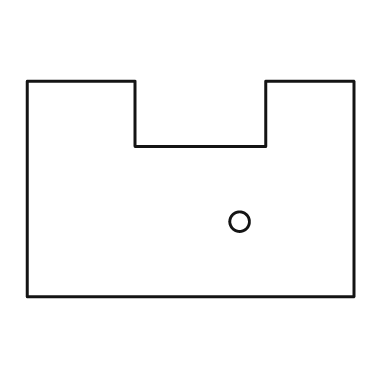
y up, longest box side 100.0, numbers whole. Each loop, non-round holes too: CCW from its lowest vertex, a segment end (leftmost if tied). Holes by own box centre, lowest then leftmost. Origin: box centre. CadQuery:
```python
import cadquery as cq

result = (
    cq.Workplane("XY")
    .moveTo(-50.0, -33.0)
    .lineTo(50.0, -33.0)
    .lineTo(50.0, 33.0)
    .lineTo(23.0, 33.0)
    .lineTo(23.0, 13.0)
    .lineTo(-17.0, 13.0)
    .lineTo(-17.0, 33.0)
    .lineTo(-50.0, 33.0)
    .close()
    .moveTo(15.0, -10.0)
    .circle(3.0)
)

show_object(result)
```